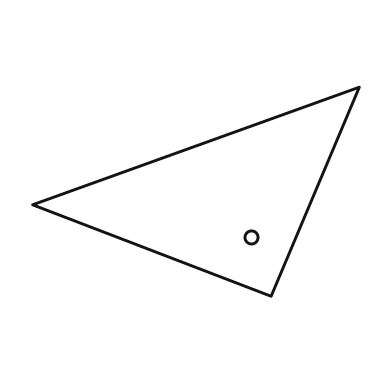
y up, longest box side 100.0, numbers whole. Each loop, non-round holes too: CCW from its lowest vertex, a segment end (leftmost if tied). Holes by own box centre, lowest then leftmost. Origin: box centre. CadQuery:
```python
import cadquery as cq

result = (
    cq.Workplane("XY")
    .moveTo(23.0, -32.0)
    .lineTo(50.0, 32.0)
    .lineTo(-50.0, -4.0)
    .close()
    .moveTo(17.0, -14.0)
    .circle(2.0)
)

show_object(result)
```